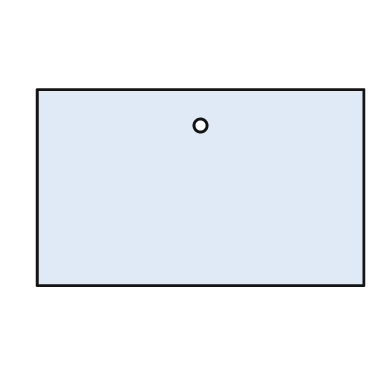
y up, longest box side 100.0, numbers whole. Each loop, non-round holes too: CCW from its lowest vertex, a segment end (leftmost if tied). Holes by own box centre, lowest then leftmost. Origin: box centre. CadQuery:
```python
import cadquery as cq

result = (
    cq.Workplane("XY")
    .moveTo(-50.0, -30.0)
    .lineTo(50.0, -30.0)
    .lineTo(50.0, 30.0)
    .lineTo(-50.0, 30.0)
    .close()
    .moveTo(0.0, 19.0)
    .circle(2.0)
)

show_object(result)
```